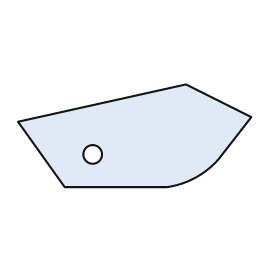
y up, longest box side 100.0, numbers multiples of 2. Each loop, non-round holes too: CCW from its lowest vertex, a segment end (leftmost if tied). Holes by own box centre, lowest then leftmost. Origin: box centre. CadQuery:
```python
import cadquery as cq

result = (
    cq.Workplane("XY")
    .moveTo(-30.0, -22.0)
    .lineTo(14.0, -22.0)
    .threePointArc((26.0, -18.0), (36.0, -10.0))
    .lineTo(50.0, 8.0)
    .lineTo(22.0, 22.0)
    .lineTo(-50.0, 6.0)
    .close()
    .moveTo(-18.0, -8.0)
    .circle(4.0)
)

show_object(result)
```